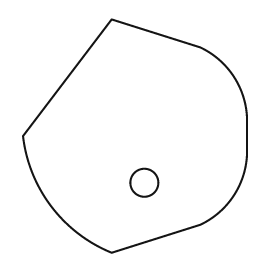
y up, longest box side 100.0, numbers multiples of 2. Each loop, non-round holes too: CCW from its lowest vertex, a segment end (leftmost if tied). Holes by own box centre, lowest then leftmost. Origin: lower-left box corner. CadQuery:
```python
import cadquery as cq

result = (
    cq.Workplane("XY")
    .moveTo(38.0, 0.0)
    .lineTo(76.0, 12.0)
    .threePointArc((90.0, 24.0), (96.0, 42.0))
    .lineTo(96.0, 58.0)
    .threePointArc((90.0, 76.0), (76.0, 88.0))
    .lineTo(38.0, 100.0)
    .lineTo(0.0, 50.0)
    .threePointArc((12.0, 20.0), (38.0, 0.0))
    .close()
    .moveTo(52.0, 30.0)
    .circle(6.0)
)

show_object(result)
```